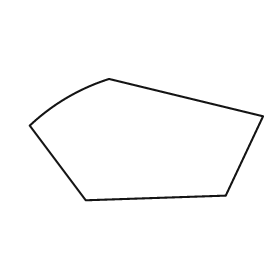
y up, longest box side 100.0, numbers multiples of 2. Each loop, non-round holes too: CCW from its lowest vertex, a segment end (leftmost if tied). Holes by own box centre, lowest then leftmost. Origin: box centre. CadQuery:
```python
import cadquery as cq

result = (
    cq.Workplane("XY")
    .moveTo(-26.0, -26.0)
    .lineTo(34.0, -24.0)
    .lineTo(50.0, 10.0)
    .lineTo(-16.0, 26.0)
    .threePointArc((-34.0, 18.0), (-50.0, 6.0))
    .close()
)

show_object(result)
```